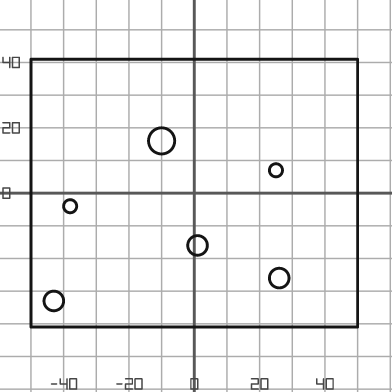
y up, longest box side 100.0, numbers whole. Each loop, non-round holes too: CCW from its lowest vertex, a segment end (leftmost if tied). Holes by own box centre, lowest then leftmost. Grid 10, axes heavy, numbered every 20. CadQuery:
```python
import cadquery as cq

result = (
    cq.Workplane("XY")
    .moveTo(-50.0, -41.0)
    .lineTo(50.0, -41.0)
    .lineTo(50.0, 41.0)
    .lineTo(-50.0, 41.0)
    .close()
    .moveTo(-43.0, -33.0)
    .circle(3.0)
    .moveTo(26.0, -26.0)
    .circle(3.0)
    .moveTo(1.0, -16.0)
    .circle(3.0)
    .moveTo(-38.0, -4.0)
    .circle(2.0)
    .moveTo(25.0, 7.0)
    .circle(2.0)
    .moveTo(-10.0, 16.0)
    .circle(4.0)
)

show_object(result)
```